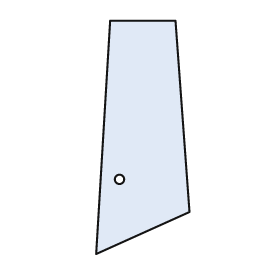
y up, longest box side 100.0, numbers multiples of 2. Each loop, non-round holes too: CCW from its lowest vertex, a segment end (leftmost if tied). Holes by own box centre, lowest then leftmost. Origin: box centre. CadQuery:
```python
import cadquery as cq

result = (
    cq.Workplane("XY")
    .moveTo(-20.0, -50.0)
    .lineTo(20.0, -32.0)
    .lineTo(14.0, 50.0)
    .lineTo(-14.0, 50.0)
    .close()
    .moveTo(-10.0, -18.0)
    .circle(2.0)
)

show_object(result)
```